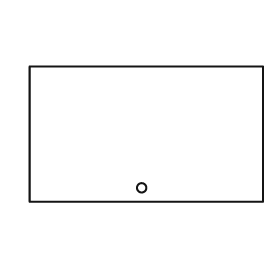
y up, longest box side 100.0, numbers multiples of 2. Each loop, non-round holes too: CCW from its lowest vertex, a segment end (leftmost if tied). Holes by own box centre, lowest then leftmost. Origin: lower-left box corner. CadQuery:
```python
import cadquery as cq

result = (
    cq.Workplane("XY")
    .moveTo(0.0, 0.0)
    .lineTo(100.0, 0.0)
    .lineTo(100.0, 58.0)
    .lineTo(0.0, 58.0)
    .close()
    .moveTo(48.0, 6.0)
    .circle(2.0)
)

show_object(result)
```